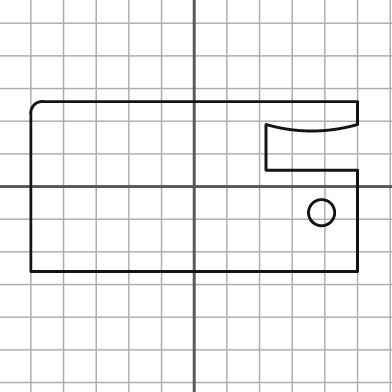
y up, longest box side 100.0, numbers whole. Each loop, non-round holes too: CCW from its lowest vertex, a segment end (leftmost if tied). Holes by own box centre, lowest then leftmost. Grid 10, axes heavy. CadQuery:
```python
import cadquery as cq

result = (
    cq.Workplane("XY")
    .moveTo(-50.0, -26.0)
    .lineTo(50.0, -26.0)
    .lineTo(50.0, 5.0)
    .lineTo(22.0, 5.0)
    .lineTo(22.0, 19.0)
    .threePointArc((36.0, 17.0), (50.0, 19.0))
    .lineTo(50.0, 26.0)
    .lineTo(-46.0, 26.0)
    .threePointArc((-49.0, 25.0), (-50.0, 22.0))
    .close()
    .moveTo(39.0, -8.0)
    .circle(4.0)
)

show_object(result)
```